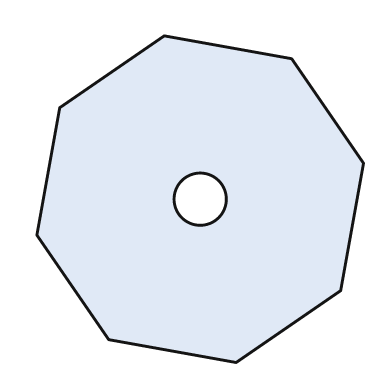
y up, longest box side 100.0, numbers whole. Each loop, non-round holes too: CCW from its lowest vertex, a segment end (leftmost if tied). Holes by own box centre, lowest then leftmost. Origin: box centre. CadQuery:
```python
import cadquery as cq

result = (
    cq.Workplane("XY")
    .moveTo(11.0, -50.0)
    .lineTo(43.0, -28.0)
    .lineTo(50.0, 11.0)
    .lineTo(28.0, 43.0)
    .lineTo(-11.0, 50.0)
    .lineTo(-43.0, 28.0)
    .lineTo(-50.0, -11.0)
    .lineTo(-28.0, -43.0)
    .close()
    .moveTo(0.0, 0.0)
    .circle(8.0)
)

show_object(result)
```